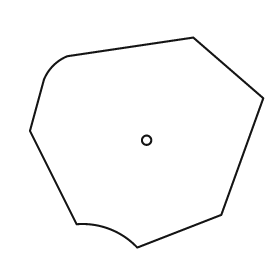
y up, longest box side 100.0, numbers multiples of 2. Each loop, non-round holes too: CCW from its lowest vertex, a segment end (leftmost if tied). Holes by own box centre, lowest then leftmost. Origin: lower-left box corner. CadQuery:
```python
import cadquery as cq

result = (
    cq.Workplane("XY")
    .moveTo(46.0, 0.0)
    .lineTo(82.0, 14.0)
    .lineTo(100.0, 64.0)
    .lineTo(70.0, 90.0)
    .lineTo(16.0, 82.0)
    .threePointArc((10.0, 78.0), (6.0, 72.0))
    .lineTo(0.0, 50.0)
    .lineTo(20.0, 10.0)
    .threePointArc((34.0, 8.0), (46.0, 0.0))
    .close()
    .moveTo(50.0, 46.0)
    .circle(2.0)
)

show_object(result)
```